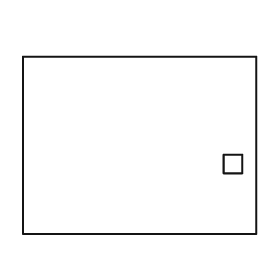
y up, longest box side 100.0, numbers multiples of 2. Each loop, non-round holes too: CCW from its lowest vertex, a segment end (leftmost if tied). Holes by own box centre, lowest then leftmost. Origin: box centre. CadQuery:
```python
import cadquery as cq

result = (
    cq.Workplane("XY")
    .moveTo(-50.0, -38.0)
    .lineTo(50.0, -38.0)
    .lineTo(50.0, 38.0)
    .lineTo(-50.0, 38.0)
    .close()
    .moveTo(36.0, -12.0)
    .lineTo(44.0, -12.0)
    .lineTo(44.0, -4.0)
    .lineTo(36.0, -4.0)
    .close()
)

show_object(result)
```